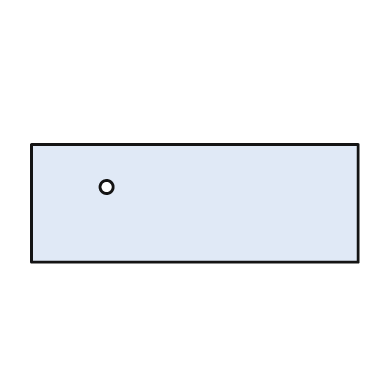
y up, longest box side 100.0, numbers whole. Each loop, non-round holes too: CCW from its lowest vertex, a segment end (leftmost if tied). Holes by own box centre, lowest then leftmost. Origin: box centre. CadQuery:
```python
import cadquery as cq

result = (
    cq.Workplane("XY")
    .moveTo(-50.0, -18.0)
    .lineTo(50.0, -18.0)
    .lineTo(50.0, 18.0)
    .lineTo(-50.0, 18.0)
    .close()
    .moveTo(-27.0, 5.0)
    .circle(2.0)
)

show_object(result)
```